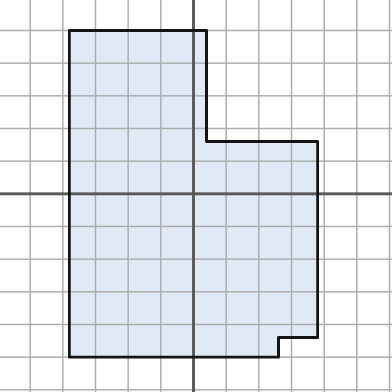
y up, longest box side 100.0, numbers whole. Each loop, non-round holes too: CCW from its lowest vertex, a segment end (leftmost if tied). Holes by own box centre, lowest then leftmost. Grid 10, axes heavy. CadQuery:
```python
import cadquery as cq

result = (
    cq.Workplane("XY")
    .moveTo(-38.0, -50.0)
    .lineTo(26.0, -50.0)
    .lineTo(26.0, -44.0)
    .lineTo(38.0, -44.0)
    .lineTo(38.0, 16.0)
    .lineTo(4.0, 16.0)
    .lineTo(4.0, 50.0)
    .lineTo(-38.0, 50.0)
    .close()
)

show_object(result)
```